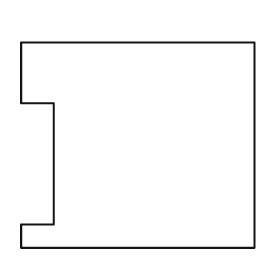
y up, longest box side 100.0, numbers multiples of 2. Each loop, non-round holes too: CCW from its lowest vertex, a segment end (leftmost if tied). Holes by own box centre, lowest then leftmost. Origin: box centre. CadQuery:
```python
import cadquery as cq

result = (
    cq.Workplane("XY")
    .moveTo(-50.0, -44.0)
    .lineTo(50.0, -44.0)
    .lineTo(50.0, 44.0)
    .lineTo(-50.0, 44.0)
    .lineTo(-50.0, 18.0)
    .lineTo(-36.0, 18.0)
    .lineTo(-36.0, -34.0)
    .lineTo(-50.0, -34.0)
    .close()
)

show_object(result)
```